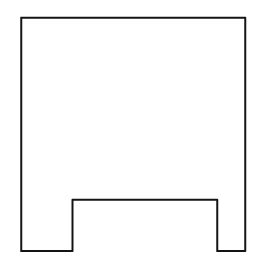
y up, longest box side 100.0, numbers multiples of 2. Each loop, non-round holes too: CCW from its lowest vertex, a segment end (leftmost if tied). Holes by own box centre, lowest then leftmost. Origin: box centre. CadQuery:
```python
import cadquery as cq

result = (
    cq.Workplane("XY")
    .moveTo(-48.0, -50.0)
    .lineTo(-26.0, -50.0)
    .lineTo(-26.0, -28.0)
    .lineTo(36.0, -28.0)
    .lineTo(36.0, -50.0)
    .lineTo(48.0, -50.0)
    .lineTo(48.0, 50.0)
    .lineTo(-48.0, 50.0)
    .close()
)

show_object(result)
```